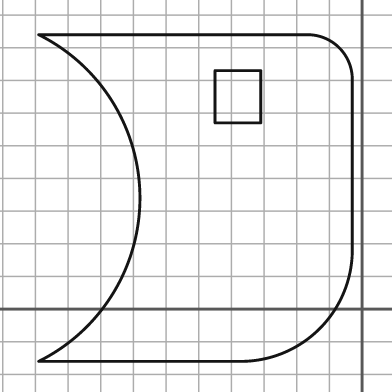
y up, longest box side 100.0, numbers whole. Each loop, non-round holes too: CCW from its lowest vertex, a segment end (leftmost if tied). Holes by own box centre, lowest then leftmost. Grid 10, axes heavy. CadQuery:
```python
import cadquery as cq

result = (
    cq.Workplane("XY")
    .moveTo(-99.0, -16.0)
    .lineTo(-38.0, -16.0)
    .threePointArc((-13.0, -6.0), (-3.0, 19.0))
    .lineTo(-3.0, 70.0)
    .threePointArc((-7.0, 80.0), (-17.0, 84.0))
    .lineTo(-99.0, 84.0)
    .threePointArc((-68.0, 34.0), (-99.0, -16.0))
    .close()
    .moveTo(-45.0, 57.0)
    .lineTo(-31.0, 57.0)
    .lineTo(-31.0, 73.0)
    .lineTo(-45.0, 73.0)
    .close()
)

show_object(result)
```